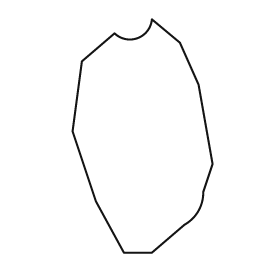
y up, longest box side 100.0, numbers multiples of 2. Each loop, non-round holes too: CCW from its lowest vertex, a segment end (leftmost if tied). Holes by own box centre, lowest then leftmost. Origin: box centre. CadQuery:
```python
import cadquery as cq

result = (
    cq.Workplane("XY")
    .moveTo(-8.0, -50.0)
    .lineTo(4.0, -50.0)
    .lineTo(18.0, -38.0)
    .threePointArc((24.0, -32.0), (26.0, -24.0))
    .lineTo(30.0, -12.0)
    .lineTo(24.0, 22.0)
    .lineTo(16.0, 40.0)
    .lineTo(4.0, 50.0)
    .threePointArc((-2.0, 42.0), (-12.0, 44.0))
    .lineTo(-26.0, 32.0)
    .lineTo(-30.0, 2.0)
    .lineTo(-20.0, -28.0)
    .close()
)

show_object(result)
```